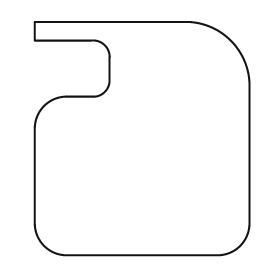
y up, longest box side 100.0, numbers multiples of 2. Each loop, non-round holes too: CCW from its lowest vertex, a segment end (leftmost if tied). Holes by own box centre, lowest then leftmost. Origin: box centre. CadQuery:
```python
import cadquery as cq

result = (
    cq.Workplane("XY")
    .moveTo(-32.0, -50.0)
    .lineTo(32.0, -50.0)
    .threePointArc((42.0, -46.0), (46.0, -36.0))
    .lineTo(46.0, 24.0)
    .threePointArc((38.0, 42.0), (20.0, 50.0))
    .lineTo(-46.0, 50.0)
    .lineTo(-46.0, 42.0)
    .lineTo(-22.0, 42.0)
    .threePointArc((-16.0, 40.0), (-14.0, 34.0))
    .lineTo(-14.0, 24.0)
    .threePointArc((-16.0, 20.0), (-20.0, 18.0))
    .lineTo(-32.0, 18.0)
    .threePointArc((-42.0, 14.0), (-46.0, 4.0))
    .lineTo(-46.0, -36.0)
    .threePointArc((-42.0, -46.0), (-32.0, -50.0))
    .close()
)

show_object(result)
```